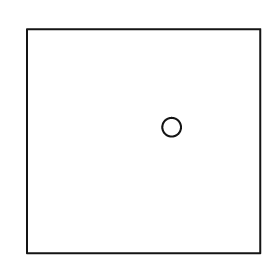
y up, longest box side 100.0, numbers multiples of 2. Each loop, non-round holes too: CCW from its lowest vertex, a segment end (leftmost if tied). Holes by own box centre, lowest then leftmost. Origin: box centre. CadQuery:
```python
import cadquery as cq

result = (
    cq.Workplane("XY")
    .moveTo(-50.0, -48.0)
    .lineTo(50.0, -48.0)
    .lineTo(50.0, 48.0)
    .lineTo(-50.0, 48.0)
    .close()
    .moveTo(12.0, 6.0)
    .circle(4.0)
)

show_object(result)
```